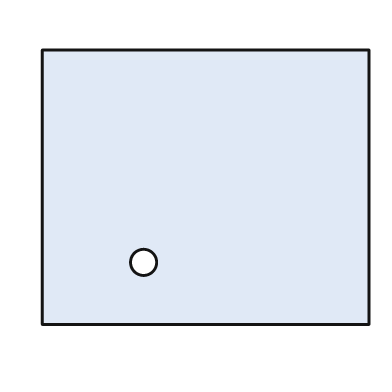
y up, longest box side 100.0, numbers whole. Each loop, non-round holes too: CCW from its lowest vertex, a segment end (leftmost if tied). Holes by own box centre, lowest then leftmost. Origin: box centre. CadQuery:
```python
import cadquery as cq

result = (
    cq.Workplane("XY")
    .moveTo(-50.0, -42.0)
    .lineTo(50.0, -42.0)
    .lineTo(50.0, 42.0)
    .lineTo(-50.0, 42.0)
    .close()
    .moveTo(-19.0, -23.0)
    .circle(4.0)
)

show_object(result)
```